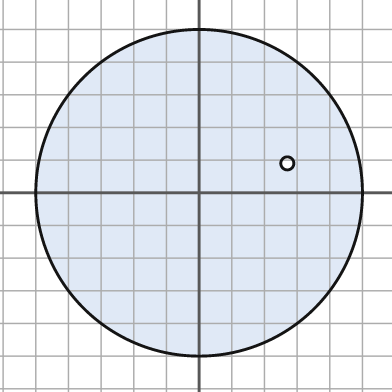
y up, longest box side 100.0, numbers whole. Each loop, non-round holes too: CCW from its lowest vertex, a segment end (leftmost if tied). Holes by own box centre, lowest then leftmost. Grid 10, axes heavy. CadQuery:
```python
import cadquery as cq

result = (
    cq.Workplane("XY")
    .moveTo(0.0, 0.0)
    .circle(50.0)
    .moveTo(27.0, 9.0)
    .circle(2.0)
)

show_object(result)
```